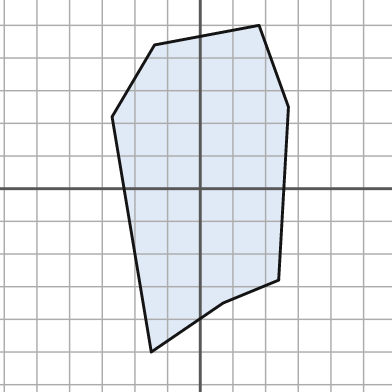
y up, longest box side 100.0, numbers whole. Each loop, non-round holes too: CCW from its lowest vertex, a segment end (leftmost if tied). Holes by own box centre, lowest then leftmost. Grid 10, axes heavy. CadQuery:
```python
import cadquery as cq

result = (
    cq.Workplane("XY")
    .moveTo(-15.0, -50.0)
    .lineTo(7.0, -35.0)
    .lineTo(24.0, -28.0)
    .lineTo(27.0, 25.0)
    .lineTo(18.0, 50.0)
    .lineTo(-14.0, 44.0)
    .lineTo(-27.0, 22.0)
    .close()
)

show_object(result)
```